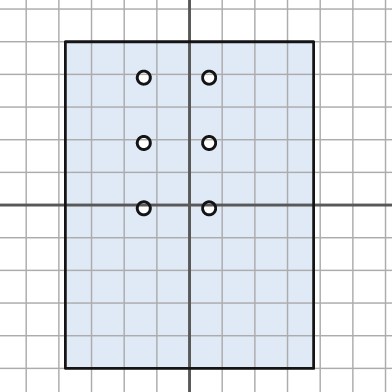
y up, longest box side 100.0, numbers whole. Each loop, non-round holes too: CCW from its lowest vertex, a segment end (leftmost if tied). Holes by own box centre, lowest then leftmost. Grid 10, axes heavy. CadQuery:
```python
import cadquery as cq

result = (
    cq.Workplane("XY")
    .moveTo(-38.0, -50.0)
    .lineTo(38.0, -50.0)
    .lineTo(38.0, 50.0)
    .lineTo(-38.0, 50.0)
    .close()
    .moveTo(-14.0, -1.0)
    .circle(2.0)
    .moveTo(6.0, -1.0)
    .circle(2.0)
    .moveTo(-14.0, 19.0)
    .circle(2.0)
    .moveTo(6.0, 19.0)
    .circle(2.0)
    .moveTo(-14.0, 39.0)
    .circle(2.0)
    .moveTo(6.0, 39.0)
    .circle(2.0)
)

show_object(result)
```